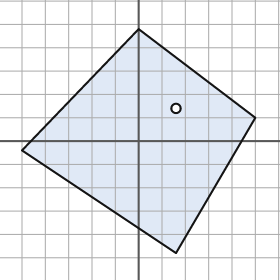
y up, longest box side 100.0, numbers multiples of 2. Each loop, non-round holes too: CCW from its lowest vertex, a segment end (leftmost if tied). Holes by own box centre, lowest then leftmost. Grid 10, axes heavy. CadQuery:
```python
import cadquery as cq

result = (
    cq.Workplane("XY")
    .moveTo(16.0, -48.0)
    .lineTo(50.0, 10.0)
    .lineTo(0.0, 48.0)
    .lineTo(-50.0, -4.0)
    .close()
    .moveTo(16.0, 14.0)
    .circle(2.0)
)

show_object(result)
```